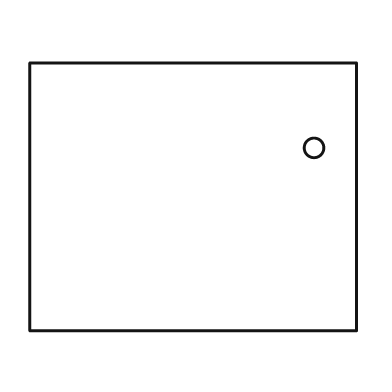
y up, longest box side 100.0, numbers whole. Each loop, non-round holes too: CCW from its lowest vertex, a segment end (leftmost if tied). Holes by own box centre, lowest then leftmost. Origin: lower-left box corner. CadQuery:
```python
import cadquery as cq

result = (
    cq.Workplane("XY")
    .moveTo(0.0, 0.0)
    .lineTo(100.0, 0.0)
    .lineTo(100.0, 82.0)
    .lineTo(0.0, 82.0)
    .close()
    .moveTo(87.0, 56.0)
    .circle(3.0)
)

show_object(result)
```